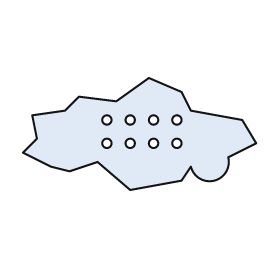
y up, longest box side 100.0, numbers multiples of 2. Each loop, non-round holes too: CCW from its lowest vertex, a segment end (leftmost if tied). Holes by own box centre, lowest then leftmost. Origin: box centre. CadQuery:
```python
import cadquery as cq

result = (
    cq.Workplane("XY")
    .moveTo(-4.0, -24.0)
    .lineTo(18.0, -20.0)
    .lineTo(22.0, -14.0)
    .threePointArc((32.0, -20.0), (38.0, -10.0))
    .lineTo(50.0, -4.0)
    .lineTo(44.0, 6.0)
    .lineTo(22.0, 10.0)
    .lineTo(18.0, 18.0)
    .lineTo(4.0, 24.0)
    .lineTo(-10.0, 14.0)
    .lineTo(-26.0, 16.0)
    .lineTo(-32.0, 10.0)
    .lineTo(-46.0, 8.0)
    .lineTo(-44.0, -2.0)
    .lineTo(-50.0, -8.0)
    .lineTo(-38.0, -14.0)
    .lineTo(-30.0, -16.0)
    .lineTo(-18.0, -12.0)
    .close()
    .moveTo(-14.0, -4.0)
    .circle(2.0)
    .moveTo(-4.0, -4.0)
    .circle(2.0)
    .moveTo(6.0, -4.0)
    .circle(2.0)
    .moveTo(16.0, -4.0)
    .circle(2.0)
    .moveTo(-14.0, 6.0)
    .circle(2.0)
    .moveTo(-4.0, 6.0)
    .circle(2.0)
    .moveTo(6.0, 6.0)
    .circle(2.0)
    .moveTo(16.0, 6.0)
    .circle(2.0)
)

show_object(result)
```